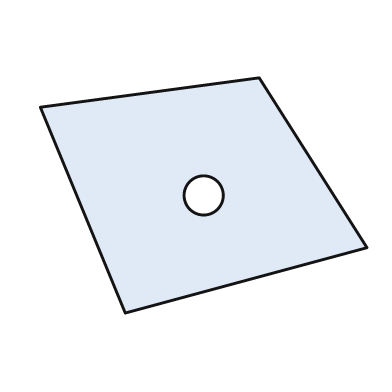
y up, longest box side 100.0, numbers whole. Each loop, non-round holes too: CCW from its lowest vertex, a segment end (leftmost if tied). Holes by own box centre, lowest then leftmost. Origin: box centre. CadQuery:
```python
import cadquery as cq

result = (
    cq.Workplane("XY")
    .moveTo(-24.0, -36.0)
    .lineTo(50.0, -16.0)
    .lineTo(17.0, 36.0)
    .lineTo(-50.0, 27.0)
    .close()
    .moveTo(0.0, 0.0)
    .circle(6.0)
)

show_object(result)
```